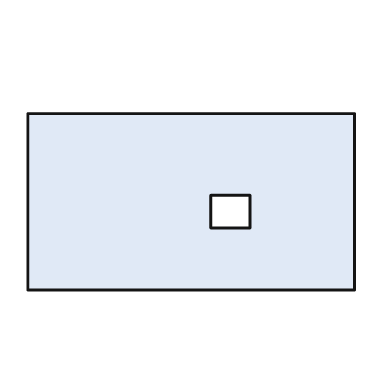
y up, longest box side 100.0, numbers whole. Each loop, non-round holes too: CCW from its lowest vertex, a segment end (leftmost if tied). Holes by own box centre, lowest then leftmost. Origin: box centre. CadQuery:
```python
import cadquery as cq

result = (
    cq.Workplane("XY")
    .moveTo(-50.0, -27.0)
    .lineTo(50.0, -27.0)
    .lineTo(50.0, 27.0)
    .lineTo(-50.0, 27.0)
    .close()
    .moveTo(6.0, -8.0)
    .lineTo(18.0, -8.0)
    .lineTo(18.0, 2.0)
    .lineTo(6.0, 2.0)
    .close()
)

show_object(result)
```